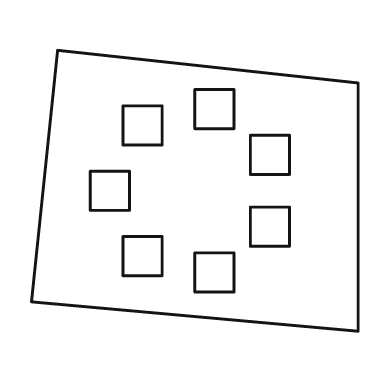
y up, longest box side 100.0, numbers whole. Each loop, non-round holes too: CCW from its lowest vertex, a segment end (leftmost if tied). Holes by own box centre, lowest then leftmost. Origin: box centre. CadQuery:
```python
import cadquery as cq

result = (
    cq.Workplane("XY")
    .moveTo(50.0, -43.0)
    .lineTo(50.0, 33.0)
    .lineTo(-42.0, 43.0)
    .lineTo(-50.0, -34.0)
    .close()
    .moveTo(0.0, -31.0)
    .lineTo(12.0, -31.0)
    .lineTo(12.0, -19.0)
    .lineTo(0.0, -19.0)
    .close()
    .moveTo(-22.0, -26.0)
    .lineTo(-10.0, -26.0)
    .lineTo(-10.0, -14.0)
    .lineTo(-22.0, -14.0)
    .close()
    .moveTo(17.0, -17.0)
    .lineTo(29.0, -17.0)
    .lineTo(29.0, -5.0)
    .lineTo(17.0, -5.0)
    .close()
    .moveTo(-32.0, -6.0)
    .lineTo(-20.0, -6.0)
    .lineTo(-20.0, 6.0)
    .lineTo(-32.0, 6.0)
    .close()
    .moveTo(17.0, 5.0)
    .lineTo(29.0, 5.0)
    .lineTo(29.0, 17.0)
    .lineTo(17.0, 17.0)
    .close()
    .moveTo(-22.0, 14.0)
    .lineTo(-10.0, 14.0)
    .lineTo(-10.0, 26.0)
    .lineTo(-22.0, 26.0)
    .close()
    .moveTo(0.0, 19.0)
    .lineTo(12.0, 19.0)
    .lineTo(12.0, 31.0)
    .lineTo(0.0, 31.0)
    .close()
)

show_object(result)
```